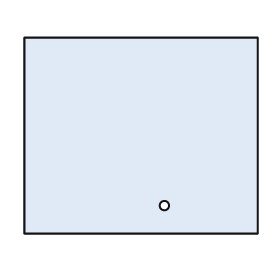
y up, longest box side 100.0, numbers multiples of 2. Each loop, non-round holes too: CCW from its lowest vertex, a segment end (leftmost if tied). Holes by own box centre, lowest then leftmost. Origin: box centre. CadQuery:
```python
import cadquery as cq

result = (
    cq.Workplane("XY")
    .moveTo(-50.0, -42.0)
    .lineTo(50.0, -42.0)
    .lineTo(50.0, 42.0)
    .lineTo(-50.0, 42.0)
    .close()
    .moveTo(10.0, -30.0)
    .circle(2.0)
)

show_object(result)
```